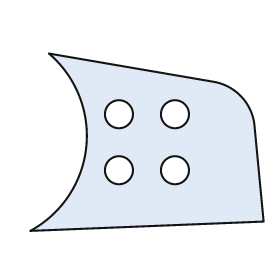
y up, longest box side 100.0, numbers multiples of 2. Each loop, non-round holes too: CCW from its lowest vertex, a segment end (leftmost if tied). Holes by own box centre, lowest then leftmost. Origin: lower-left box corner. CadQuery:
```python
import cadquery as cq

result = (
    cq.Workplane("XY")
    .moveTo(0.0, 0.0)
    .lineTo(100.0, 4.0)
    .lineTo(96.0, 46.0)
    .threePointArc((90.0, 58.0), (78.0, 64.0))
    .lineTo(8.0, 76.0)
    .threePointArc((24.0, 36.0), (0.0, 0.0))
    .close()
    .moveTo(38.0, 26.0)
    .circle(6.0)
    .moveTo(62.0, 26.0)
    .circle(6.0)
    .moveTo(38.0, 50.0)
    .circle(6.0)
    .moveTo(62.0, 50.0)
    .circle(6.0)
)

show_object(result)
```